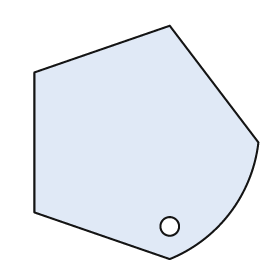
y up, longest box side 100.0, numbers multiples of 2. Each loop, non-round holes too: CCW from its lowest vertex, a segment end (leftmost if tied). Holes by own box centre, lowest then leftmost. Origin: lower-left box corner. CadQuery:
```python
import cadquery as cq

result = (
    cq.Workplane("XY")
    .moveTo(58.0, 0.0)
    .threePointArc((84.0, 20.0), (96.0, 50.0))
    .lineTo(58.0, 100.0)
    .lineTo(0.0, 80.0)
    .lineTo(0.0, 20.0)
    .close()
    .moveTo(58.0, 14.0)
    .circle(4.0)
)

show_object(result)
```